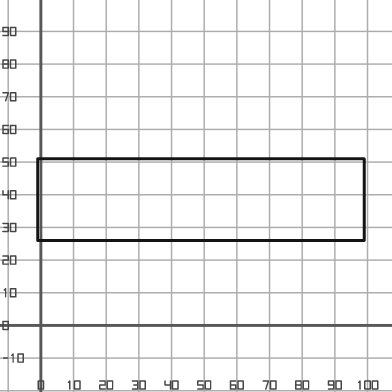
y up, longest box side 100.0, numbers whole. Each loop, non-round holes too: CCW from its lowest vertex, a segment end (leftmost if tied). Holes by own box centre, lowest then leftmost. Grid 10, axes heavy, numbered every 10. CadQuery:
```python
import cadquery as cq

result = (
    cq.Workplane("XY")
    .moveTo(-1.0, 26.0)
    .lineTo(99.0, 26.0)
    .lineTo(99.0, 51.0)
    .lineTo(-1.0, 51.0)
    .close()
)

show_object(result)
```